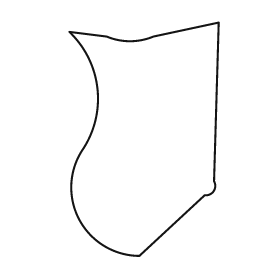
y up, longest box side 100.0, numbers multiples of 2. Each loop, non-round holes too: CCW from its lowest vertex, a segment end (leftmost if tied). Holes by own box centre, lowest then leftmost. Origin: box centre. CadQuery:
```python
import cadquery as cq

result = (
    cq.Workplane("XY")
    .moveTo(-2.0, -50.0)
    .lineTo(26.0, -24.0)
    .threePointArc((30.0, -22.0), (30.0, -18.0))
    .lineTo(32.0, 50.0)
    .lineTo(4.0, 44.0)
    .threePointArc((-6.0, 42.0), (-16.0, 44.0))
    .lineTo(-32.0, 46.0)
    .threePointArc((-20.0, 22.0), (-26.0, -4.0))
    .threePointArc((-28.0, -34.0), (-2.0, -50.0))
    .close()
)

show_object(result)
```